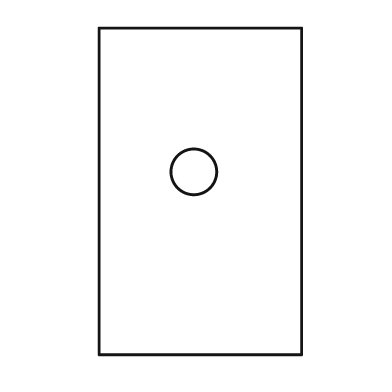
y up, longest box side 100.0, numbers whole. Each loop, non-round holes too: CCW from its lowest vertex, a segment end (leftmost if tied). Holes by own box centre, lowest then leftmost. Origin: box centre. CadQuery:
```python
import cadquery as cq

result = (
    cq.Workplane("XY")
    .moveTo(-31.0, -50.0)
    .lineTo(31.0, -50.0)
    .lineTo(31.0, 50.0)
    .lineTo(-31.0, 50.0)
    .close()
    .moveTo(-2.0, 6.0)
    .circle(7.0)
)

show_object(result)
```